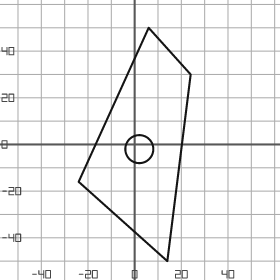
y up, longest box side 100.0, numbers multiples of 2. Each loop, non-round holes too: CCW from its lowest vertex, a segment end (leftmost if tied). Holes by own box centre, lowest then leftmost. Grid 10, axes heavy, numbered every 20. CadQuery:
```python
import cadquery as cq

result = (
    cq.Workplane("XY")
    .moveTo(14.0, -50.0)
    .lineTo(24.0, 30.0)
    .lineTo(6.0, 50.0)
    .lineTo(-24.0, -16.0)
    .close()
    .moveTo(2.0, -2.0)
    .circle(6.0)
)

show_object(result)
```